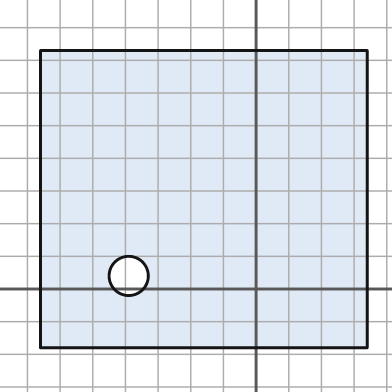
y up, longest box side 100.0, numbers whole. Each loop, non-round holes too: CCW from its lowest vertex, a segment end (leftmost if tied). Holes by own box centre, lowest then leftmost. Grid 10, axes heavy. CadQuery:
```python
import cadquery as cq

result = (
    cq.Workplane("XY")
    .moveTo(-66.0, -18.0)
    .lineTo(34.0, -18.0)
    .lineTo(34.0, 73.0)
    .lineTo(-66.0, 73.0)
    .close()
    .moveTo(-39.0, 4.0)
    .circle(6.0)
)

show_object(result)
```